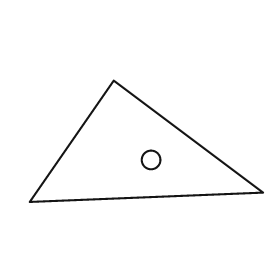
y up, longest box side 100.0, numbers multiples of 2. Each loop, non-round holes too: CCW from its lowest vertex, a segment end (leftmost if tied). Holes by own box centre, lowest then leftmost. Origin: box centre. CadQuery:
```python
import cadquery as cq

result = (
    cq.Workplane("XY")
    .moveTo(-50.0, -26.0)
    .lineTo(50.0, -22.0)
    .lineTo(-14.0, 26.0)
    .close()
    .moveTo(2.0, -8.0)
    .circle(4.0)
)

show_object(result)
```